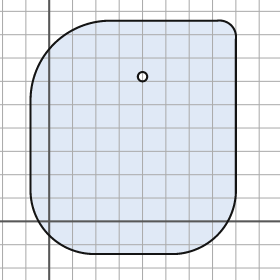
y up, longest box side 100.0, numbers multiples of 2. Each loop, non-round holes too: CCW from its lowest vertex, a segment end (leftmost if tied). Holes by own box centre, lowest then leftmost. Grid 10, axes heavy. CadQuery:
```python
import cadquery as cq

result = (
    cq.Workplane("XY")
    .moveTo(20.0, -14.0)
    .lineTo(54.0, -14.0)
    .threePointArc((72.0, -6.0), (80.0, 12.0))
    .lineTo(80.0, 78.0)
    .threePointArc((78.0, 84.0), (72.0, 86.0))
    .lineTo(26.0, 86.0)
    .threePointArc((2.0, 76.0), (-8.0, 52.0))
    .lineTo(-8.0, 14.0)
    .threePointArc((0.0, -6.0), (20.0, -14.0))
    .close()
    .moveTo(40.0, 62.0)
    .circle(2.0)
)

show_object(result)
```